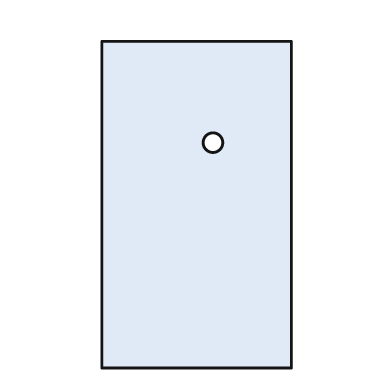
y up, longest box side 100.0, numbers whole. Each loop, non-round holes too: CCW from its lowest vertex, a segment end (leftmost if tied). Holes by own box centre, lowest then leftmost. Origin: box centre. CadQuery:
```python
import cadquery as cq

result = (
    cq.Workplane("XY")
    .moveTo(-29.0, -50.0)
    .lineTo(29.0, -50.0)
    .lineTo(29.0, 50.0)
    .lineTo(-29.0, 50.0)
    .close()
    .moveTo(5.0, 19.0)
    .circle(3.0)
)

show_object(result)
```